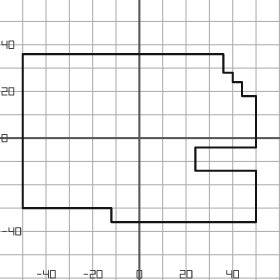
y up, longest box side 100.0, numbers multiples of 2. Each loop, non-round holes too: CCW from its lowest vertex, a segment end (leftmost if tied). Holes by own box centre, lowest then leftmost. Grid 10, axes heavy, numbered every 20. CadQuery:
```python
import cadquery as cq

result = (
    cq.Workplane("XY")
    .moveTo(-12.0, -36.0)
    .lineTo(50.0, -36.0)
    .lineTo(50.0, -14.0)
    .lineTo(24.0, -14.0)
    .lineTo(24.0, -4.0)
    .lineTo(50.0, -4.0)
    .lineTo(50.0, 18.0)
    .lineTo(44.0, 18.0)
    .lineTo(44.0, 24.0)
    .lineTo(40.0, 24.0)
    .lineTo(40.0, 28.0)
    .lineTo(36.0, 28.0)
    .lineTo(36.0, 36.0)
    .lineTo(-50.0, 36.0)
    .lineTo(-50.0, -30.0)
    .lineTo(-12.0, -30.0)
    .close()
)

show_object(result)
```